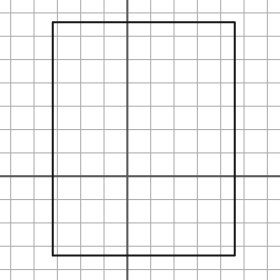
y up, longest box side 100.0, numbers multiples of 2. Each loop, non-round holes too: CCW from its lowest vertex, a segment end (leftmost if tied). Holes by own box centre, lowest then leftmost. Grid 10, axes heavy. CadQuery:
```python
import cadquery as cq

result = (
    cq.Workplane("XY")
    .moveTo(-32.0, -34.0)
    .lineTo(46.0, -34.0)
    .lineTo(46.0, 66.0)
    .lineTo(-32.0, 66.0)
    .close()
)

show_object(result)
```